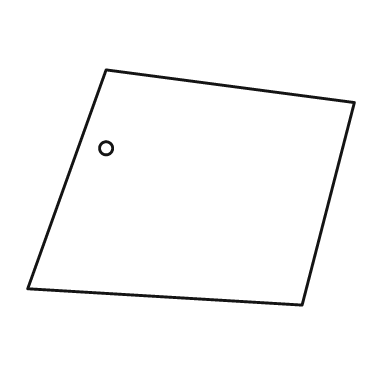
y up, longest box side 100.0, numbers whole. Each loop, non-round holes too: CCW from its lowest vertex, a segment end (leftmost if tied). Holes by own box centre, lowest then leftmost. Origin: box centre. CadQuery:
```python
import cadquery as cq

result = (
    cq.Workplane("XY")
    .moveTo(34.0, -36.0)
    .lineTo(50.0, 26.0)
    .lineTo(-26.0, 36.0)
    .lineTo(-50.0, -31.0)
    .close()
    .moveTo(-26.0, 12.0)
    .circle(2.0)
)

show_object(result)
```